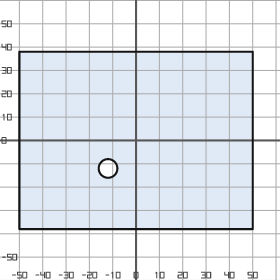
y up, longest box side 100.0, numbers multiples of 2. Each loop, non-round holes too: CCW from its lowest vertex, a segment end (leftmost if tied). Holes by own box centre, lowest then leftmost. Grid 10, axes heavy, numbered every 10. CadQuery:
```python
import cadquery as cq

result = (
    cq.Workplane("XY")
    .moveTo(-50.0, -38.0)
    .lineTo(50.0, -38.0)
    .lineTo(50.0, 38.0)
    .lineTo(-50.0, 38.0)
    .close()
    .moveTo(-12.0, -12.0)
    .circle(4.0)
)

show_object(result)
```